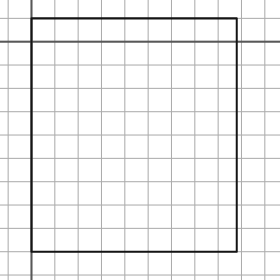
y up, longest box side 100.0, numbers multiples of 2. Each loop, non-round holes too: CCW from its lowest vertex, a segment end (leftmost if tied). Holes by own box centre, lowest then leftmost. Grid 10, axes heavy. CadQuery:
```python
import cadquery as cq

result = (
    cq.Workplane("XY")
    .moveTo(0.0, -90.0)
    .lineTo(88.0, -90.0)
    .lineTo(88.0, 10.0)
    .lineTo(0.0, 10.0)
    .close()
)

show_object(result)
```